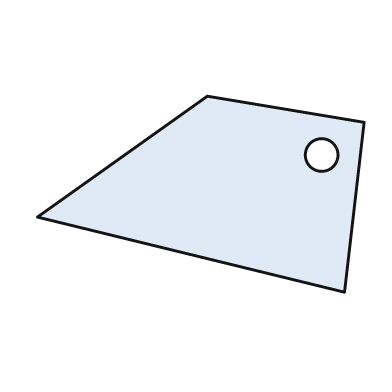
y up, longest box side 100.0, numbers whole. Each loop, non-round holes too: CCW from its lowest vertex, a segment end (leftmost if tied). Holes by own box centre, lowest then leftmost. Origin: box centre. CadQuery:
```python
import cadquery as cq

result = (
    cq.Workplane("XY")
    .moveTo(44.0, -30.0)
    .lineTo(50.0, 22.0)
    .lineTo(2.0, 30.0)
    .lineTo(-50.0, -7.0)
    .close()
    .moveTo(37.0, 12.0)
    .circle(5.0)
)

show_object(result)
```